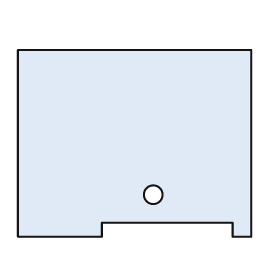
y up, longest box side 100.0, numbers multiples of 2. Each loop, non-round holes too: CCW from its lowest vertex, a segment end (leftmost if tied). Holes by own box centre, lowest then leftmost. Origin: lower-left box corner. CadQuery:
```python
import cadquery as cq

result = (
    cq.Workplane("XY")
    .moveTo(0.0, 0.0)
    .lineTo(36.0, 0.0)
    .lineTo(36.0, 6.0)
    .lineTo(92.0, 6.0)
    .lineTo(92.0, 0.0)
    .lineTo(100.0, 0.0)
    .lineTo(100.0, 80.0)
    .lineTo(0.0, 80.0)
    .close()
    .moveTo(58.0, 18.0)
    .circle(4.0)
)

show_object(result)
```